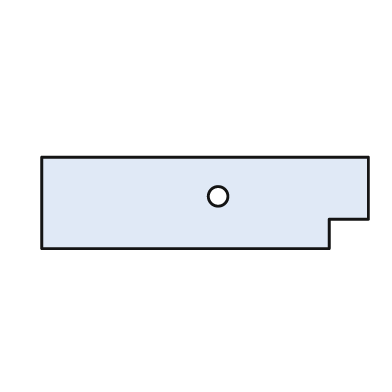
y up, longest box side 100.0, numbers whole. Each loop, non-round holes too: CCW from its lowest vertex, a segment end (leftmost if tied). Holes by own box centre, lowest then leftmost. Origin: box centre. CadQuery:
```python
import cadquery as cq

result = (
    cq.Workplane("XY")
    .moveTo(-50.0, -14.0)
    .lineTo(38.0, -14.0)
    .lineTo(38.0, -5.0)
    .lineTo(50.0, -5.0)
    .lineTo(50.0, 14.0)
    .lineTo(-50.0, 14.0)
    .close()
    .moveTo(4.0, 2.0)
    .circle(3.0)
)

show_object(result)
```